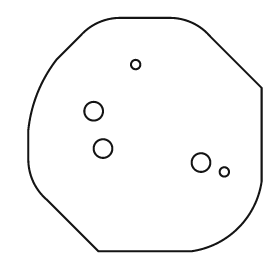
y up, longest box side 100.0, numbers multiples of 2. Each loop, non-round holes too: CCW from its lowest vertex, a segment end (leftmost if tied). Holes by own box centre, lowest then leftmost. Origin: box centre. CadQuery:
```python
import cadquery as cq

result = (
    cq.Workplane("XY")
    .moveTo(-20.0, -50.0)
    .lineTo(20.0, -50.0)
    .threePointArc((40.0, -40.0), (50.0, -20.0))
    .lineTo(50.0, 20.0)
    .lineTo(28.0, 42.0)
    .threePointArc((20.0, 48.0), (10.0, 50.0))
    .lineTo(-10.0, 50.0)
    .threePointArc((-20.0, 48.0), (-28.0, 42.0))
    .lineTo(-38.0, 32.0)
    .threePointArc((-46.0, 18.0), (-50.0, 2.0))
    .lineTo(-50.0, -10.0)
    .threePointArc((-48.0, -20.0), (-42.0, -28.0))
    .close()
    .moveTo(34.0, -16.0)
    .circle(2.0)
    .moveTo(24.0, -12.0)
    .circle(4.0)
    .moveTo(-18.0, -6.0)
    .circle(4.0)
    .moveTo(-22.0, 10.0)
    .circle(4.0)
    .moveTo(-4.0, 30.0)
    .circle(2.0)
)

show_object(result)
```